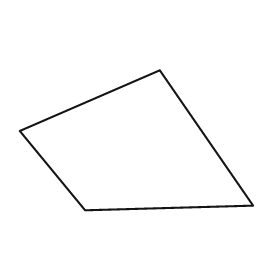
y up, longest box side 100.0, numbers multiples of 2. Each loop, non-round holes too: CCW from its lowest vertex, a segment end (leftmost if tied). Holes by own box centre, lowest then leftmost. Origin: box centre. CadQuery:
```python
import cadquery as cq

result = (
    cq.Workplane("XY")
    .moveTo(-22.0, -30.0)
    .lineTo(50.0, -28.0)
    .lineTo(10.0, 30.0)
    .lineTo(-50.0, 4.0)
    .close()
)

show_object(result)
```